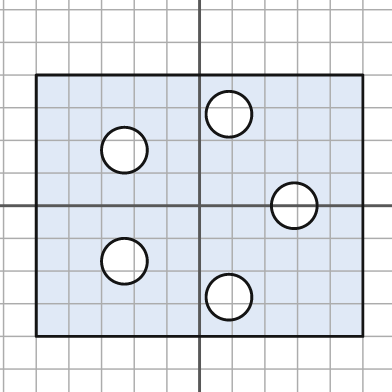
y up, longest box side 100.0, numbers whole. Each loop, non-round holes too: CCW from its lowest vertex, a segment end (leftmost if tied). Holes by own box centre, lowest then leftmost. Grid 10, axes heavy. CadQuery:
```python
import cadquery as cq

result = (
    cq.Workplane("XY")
    .moveTo(-50.0, -40.0)
    .lineTo(50.0, -40.0)
    .lineTo(50.0, 40.0)
    .lineTo(-50.0, 40.0)
    .close()
    .moveTo(9.0, -28.0)
    .circle(7.0)
    .moveTo(-23.0, -17.0)
    .circle(7.0)
    .moveTo(29.0, 0.0)
    .circle(7.0)
    .moveTo(-23.0, 17.0)
    .circle(7.0)
    .moveTo(9.0, 28.0)
    .circle(7.0)
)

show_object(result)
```